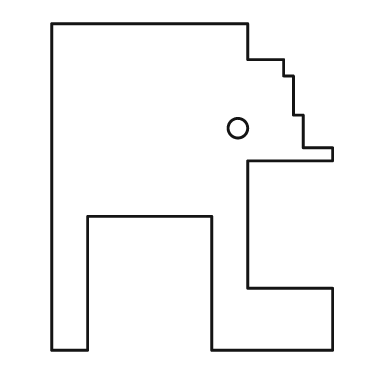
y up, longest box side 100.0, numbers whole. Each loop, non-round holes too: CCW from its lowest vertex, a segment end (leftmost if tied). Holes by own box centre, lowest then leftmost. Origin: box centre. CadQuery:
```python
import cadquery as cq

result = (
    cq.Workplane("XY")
    .moveTo(-43.0, -50.0)
    .lineTo(-32.0, -50.0)
    .lineTo(-32.0, -9.0)
    .lineTo(6.0, -9.0)
    .lineTo(6.0, -50.0)
    .lineTo(43.0, -50.0)
    .lineTo(43.0, -31.0)
    .lineTo(17.0, -31.0)
    .lineTo(17.0, 8.0)
    .lineTo(43.0, 8.0)
    .lineTo(43.0, 12.0)
    .lineTo(34.0, 12.0)
    .lineTo(34.0, 22.0)
    .lineTo(31.0, 22.0)
    .lineTo(31.0, 34.0)
    .lineTo(28.0, 34.0)
    .lineTo(28.0, 39.0)
    .lineTo(17.0, 39.0)
    .lineTo(17.0, 50.0)
    .lineTo(-43.0, 50.0)
    .close()
    .moveTo(14.0, 18.0)
    .circle(3.0)
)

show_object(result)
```